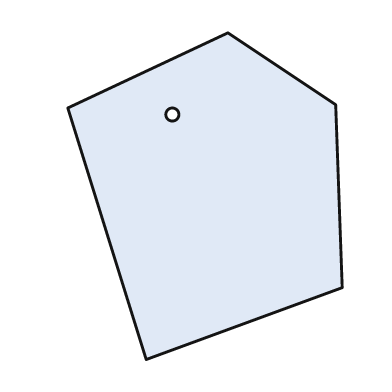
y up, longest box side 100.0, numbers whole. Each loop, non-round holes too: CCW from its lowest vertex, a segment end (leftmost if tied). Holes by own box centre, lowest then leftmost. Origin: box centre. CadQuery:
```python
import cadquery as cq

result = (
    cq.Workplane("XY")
    .moveTo(-18.0, -50.0)
    .lineTo(42.0, -28.0)
    .lineTo(40.0, 28.0)
    .lineTo(7.0, 50.0)
    .lineTo(-42.0, 27.0)
    .close()
    .moveTo(-10.0, 25.0)
    .circle(2.0)
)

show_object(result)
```